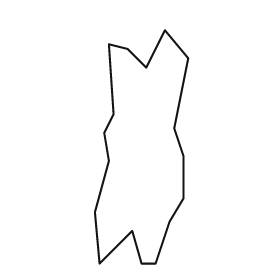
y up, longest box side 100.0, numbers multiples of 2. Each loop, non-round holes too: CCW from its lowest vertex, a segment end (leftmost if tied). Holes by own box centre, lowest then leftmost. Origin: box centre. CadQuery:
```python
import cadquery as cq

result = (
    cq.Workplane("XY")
    .moveTo(-18.0, -50.0)
    .lineTo(-4.0, -36.0)
    .lineTo(0.0, -50.0)
    .lineTo(6.0, -50.0)
    .lineTo(12.0, -32.0)
    .lineTo(18.0, -22.0)
    .lineTo(18.0, -4.0)
    .lineTo(14.0, 8.0)
    .lineTo(20.0, 38.0)
    .lineTo(10.0, 50.0)
    .lineTo(2.0, 34.0)
    .lineTo(-6.0, 42.0)
    .lineTo(-14.0, 44.0)
    .lineTo(-12.0, 14.0)
    .lineTo(-16.0, 6.0)
    .lineTo(-14.0, -6.0)
    .lineTo(-20.0, -28.0)
    .close()
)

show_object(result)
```